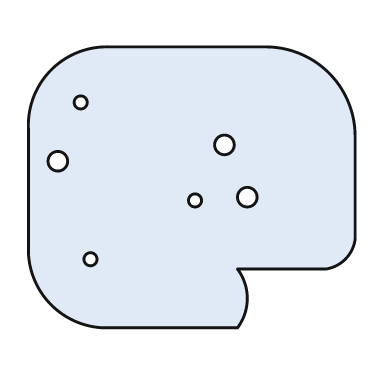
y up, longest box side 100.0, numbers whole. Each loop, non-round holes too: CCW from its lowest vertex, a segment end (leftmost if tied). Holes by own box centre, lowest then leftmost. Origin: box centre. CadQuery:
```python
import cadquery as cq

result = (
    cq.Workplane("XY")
    .moveTo(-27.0, -43.0)
    .lineTo(14.0, -43.0)
    .threePointArc((17.0, -34.0), (14.0, -25.0))
    .lineTo(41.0, -25.0)
    .threePointArc((47.0, -22.0), (50.0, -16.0))
    .lineTo(50.0, 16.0)
    .threePointArc((42.0, 35.0), (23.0, 43.0))
    .lineTo(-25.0, 43.0)
    .threePointArc((-43.0, 36.0), (-50.0, 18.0))
    .lineTo(-50.0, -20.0)
    .threePointArc((-43.0, -36.0), (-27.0, -43.0))
    .close()
    .moveTo(-31.0, -22.0)
    .circle(2.0)
    .moveTo(1.0, -4.0)
    .circle(2.0)
    .moveTo(17.0, -3.0)
    .circle(3.0)
    .moveTo(-41.0, 8.0)
    .circle(3.0)
    .moveTo(10.0, 13.0)
    .circle(3.0)
    .moveTo(-34.0, 26.0)
    .circle(2.0)
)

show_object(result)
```